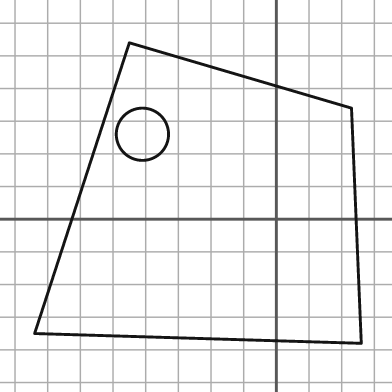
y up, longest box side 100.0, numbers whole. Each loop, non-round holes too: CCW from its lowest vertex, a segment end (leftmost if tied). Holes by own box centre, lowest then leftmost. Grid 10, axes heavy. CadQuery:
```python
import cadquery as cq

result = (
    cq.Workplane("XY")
    .moveTo(26.0, -38.0)
    .lineTo(23.0, 34.0)
    .lineTo(-45.0, 54.0)
    .lineTo(-74.0, -35.0)
    .close()
    .moveTo(-41.0, 26.0)
    .circle(8.0)
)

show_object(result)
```